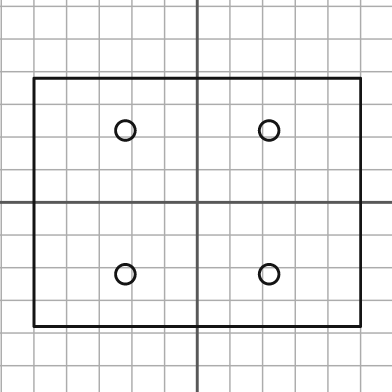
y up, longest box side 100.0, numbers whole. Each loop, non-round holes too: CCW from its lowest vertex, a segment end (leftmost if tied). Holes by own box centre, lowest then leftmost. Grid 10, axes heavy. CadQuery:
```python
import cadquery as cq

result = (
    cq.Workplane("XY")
    .moveTo(-50.0, -38.0)
    .lineTo(50.0, -38.0)
    .lineTo(50.0, 38.0)
    .lineTo(-50.0, 38.0)
    .close()
    .moveTo(-22.0, -22.0)
    .circle(3.0)
    .moveTo(22.0, -22.0)
    .circle(3.0)
    .moveTo(-22.0, 22.0)
    .circle(3.0)
    .moveTo(22.0, 22.0)
    .circle(3.0)
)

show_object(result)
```